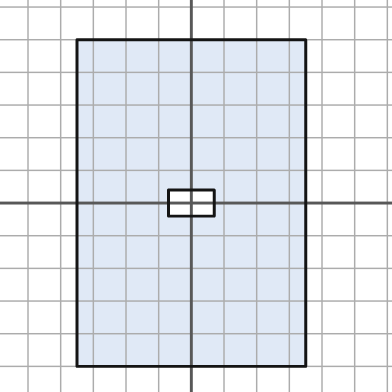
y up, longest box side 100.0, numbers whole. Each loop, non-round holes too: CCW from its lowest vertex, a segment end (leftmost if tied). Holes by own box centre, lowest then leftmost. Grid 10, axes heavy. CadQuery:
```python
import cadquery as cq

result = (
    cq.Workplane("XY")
    .moveTo(-35.0, -50.0)
    .lineTo(35.0, -50.0)
    .lineTo(35.0, 50.0)
    .lineTo(-35.0, 50.0)
    .close()
    .moveTo(-7.0, -4.0)
    .lineTo(7.0, -4.0)
    .lineTo(7.0, 4.0)
    .lineTo(-7.0, 4.0)
    .close()
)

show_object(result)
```